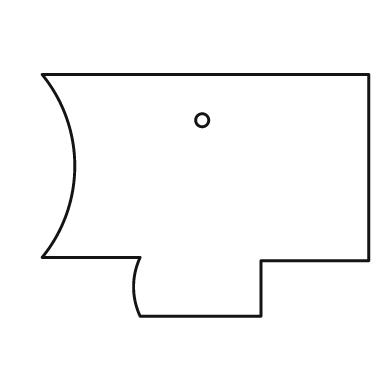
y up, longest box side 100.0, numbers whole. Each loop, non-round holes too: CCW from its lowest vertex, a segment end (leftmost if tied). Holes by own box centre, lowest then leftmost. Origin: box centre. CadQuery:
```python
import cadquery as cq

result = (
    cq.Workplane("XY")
    .moveTo(-20.0, -37.0)
    .lineTo(17.0, -37.0)
    .lineTo(17.0, -20.0)
    .lineTo(50.0, -20.0)
    .lineTo(50.0, 37.0)
    .lineTo(-50.0, 37.0)
    .threePointArc((-40.0, 9.0), (-50.0, -19.0))
    .lineTo(-20.0, -19.0)
    .threePointArc((-22.0, -28.0), (-20.0, -37.0))
    .close()
    .moveTo(-1.0, 23.0)
    .circle(2.0)
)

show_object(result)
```